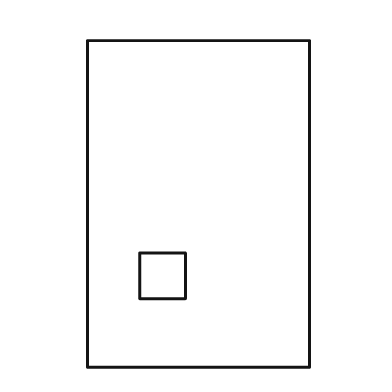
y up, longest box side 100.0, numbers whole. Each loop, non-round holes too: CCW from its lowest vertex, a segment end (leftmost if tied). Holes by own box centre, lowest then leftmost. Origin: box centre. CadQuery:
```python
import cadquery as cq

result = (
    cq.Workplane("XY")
    .moveTo(-34.0, -50.0)
    .lineTo(34.0, -50.0)
    .lineTo(34.0, 50.0)
    .lineTo(-34.0, 50.0)
    .close()
    .moveTo(-18.0, -29.0)
    .lineTo(-4.0, -29.0)
    .lineTo(-4.0, -15.0)
    .lineTo(-18.0, -15.0)
    .close()
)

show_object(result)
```